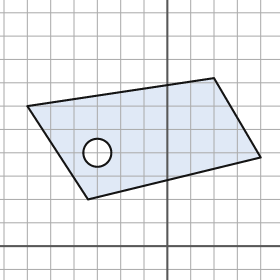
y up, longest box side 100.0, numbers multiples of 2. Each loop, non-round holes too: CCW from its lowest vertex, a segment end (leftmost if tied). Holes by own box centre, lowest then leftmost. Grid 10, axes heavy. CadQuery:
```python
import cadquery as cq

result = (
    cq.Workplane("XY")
    .moveTo(-34.0, 20.0)
    .lineTo(40.0, 38.0)
    .lineTo(20.0, 72.0)
    .lineTo(-60.0, 60.0)
    .close()
    .moveTo(-30.0, 40.0)
    .circle(6.0)
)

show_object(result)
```